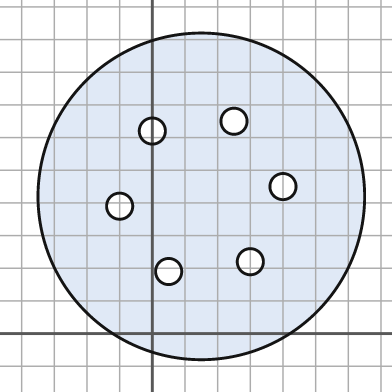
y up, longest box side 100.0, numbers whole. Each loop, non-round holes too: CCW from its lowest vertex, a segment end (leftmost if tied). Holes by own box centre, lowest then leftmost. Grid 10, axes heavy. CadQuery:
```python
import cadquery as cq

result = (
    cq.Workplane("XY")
    .moveTo(15.0, 42.0)
    .circle(50.0)
    .moveTo(5.0, 19.0)
    .circle(4.0)
    .moveTo(30.0, 22.0)
    .circle(4.0)
    .moveTo(-10.0, 39.0)
    .circle(4.0)
    .moveTo(40.0, 45.0)
    .circle(4.0)
    .moveTo(0.0, 62.0)
    .circle(4.0)
    .moveTo(25.0, 65.0)
    .circle(4.0)
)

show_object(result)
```